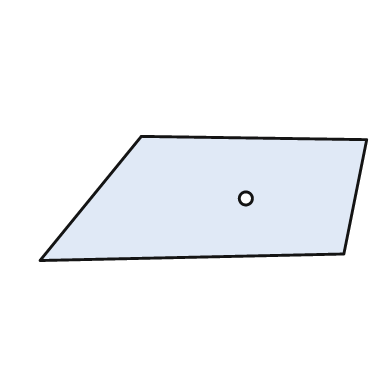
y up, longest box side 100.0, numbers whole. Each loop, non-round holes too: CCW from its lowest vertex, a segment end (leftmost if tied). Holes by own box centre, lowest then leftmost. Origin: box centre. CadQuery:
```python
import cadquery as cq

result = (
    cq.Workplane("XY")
    .moveTo(-50.0, -19.0)
    .lineTo(43.0, -17.0)
    .lineTo(50.0, 18.0)
    .lineTo(-19.0, 19.0)
    .close()
    .moveTo(13.0, 0.0)
    .circle(2.0)
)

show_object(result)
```